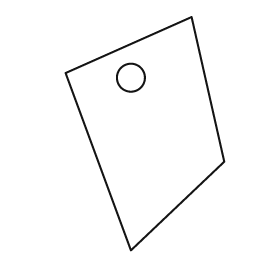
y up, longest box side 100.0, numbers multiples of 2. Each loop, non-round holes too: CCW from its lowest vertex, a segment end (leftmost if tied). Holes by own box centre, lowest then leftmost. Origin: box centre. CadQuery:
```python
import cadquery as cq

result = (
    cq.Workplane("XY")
    .moveTo(-6.0, -50.0)
    .lineTo(34.0, -12.0)
    .lineTo(20.0, 50.0)
    .lineTo(-34.0, 26.0)
    .close()
    .moveTo(-6.0, 24.0)
    .circle(6.0)
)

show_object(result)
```